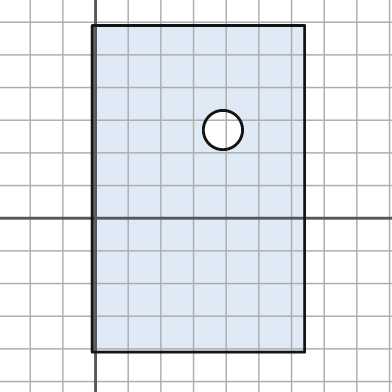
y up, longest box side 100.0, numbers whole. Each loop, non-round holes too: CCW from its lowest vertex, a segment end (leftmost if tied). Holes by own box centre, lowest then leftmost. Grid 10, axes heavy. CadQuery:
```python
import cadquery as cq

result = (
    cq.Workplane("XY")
    .moveTo(-1.0, -41.0)
    .lineTo(64.0, -41.0)
    .lineTo(64.0, 59.0)
    .lineTo(-1.0, 59.0)
    .close()
    .moveTo(39.0, 27.0)
    .circle(6.0)
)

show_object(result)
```